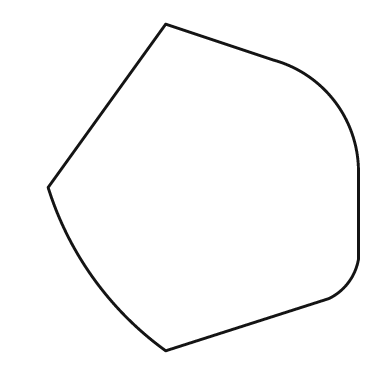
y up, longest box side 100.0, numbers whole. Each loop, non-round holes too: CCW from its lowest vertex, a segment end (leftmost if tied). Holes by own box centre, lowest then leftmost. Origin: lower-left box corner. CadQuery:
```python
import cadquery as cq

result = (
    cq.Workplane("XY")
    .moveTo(36.0, 0.0)
    .lineTo(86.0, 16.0)
    .threePointArc((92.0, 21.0), (95.0, 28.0))
    .lineTo(95.0, 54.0)
    .threePointArc((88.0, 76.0), (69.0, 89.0))
    .lineTo(36.0, 100.0)
    .lineTo(0.0, 50.0)
    .threePointArc((14.0, 22.0), (36.0, 0.0))
    .close()
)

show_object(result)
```